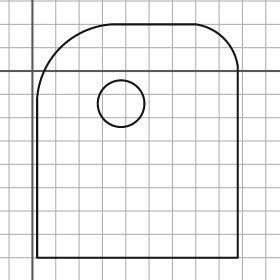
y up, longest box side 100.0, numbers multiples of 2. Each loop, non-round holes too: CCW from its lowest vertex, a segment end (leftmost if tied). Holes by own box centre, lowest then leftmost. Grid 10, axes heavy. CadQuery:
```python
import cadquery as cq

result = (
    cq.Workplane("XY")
    .moveTo(2.0, -80.0)
    .lineTo(88.0, -80.0)
    .lineTo(88.0, 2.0)
    .threePointArc((82.0, 14.0), (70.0, 20.0))
    .lineTo(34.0, 20.0)
    .threePointArc((12.0, 10.0), (2.0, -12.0))
    .close()
    .moveTo(38.0, -14.0)
    .circle(10.0)
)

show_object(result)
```